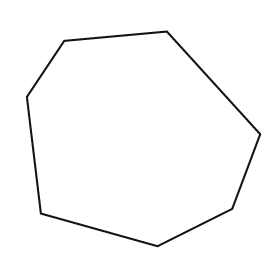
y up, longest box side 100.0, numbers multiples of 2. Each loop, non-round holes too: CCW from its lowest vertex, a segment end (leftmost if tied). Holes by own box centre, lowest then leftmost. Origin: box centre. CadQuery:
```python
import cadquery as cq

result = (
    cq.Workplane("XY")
    .moveTo(6.0, -46.0)
    .lineTo(38.0, -30.0)
    .lineTo(50.0, 2.0)
    .lineTo(10.0, 46.0)
    .lineTo(-34.0, 42.0)
    .lineTo(-50.0, 18.0)
    .lineTo(-44.0, -32.0)
    .close()
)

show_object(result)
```